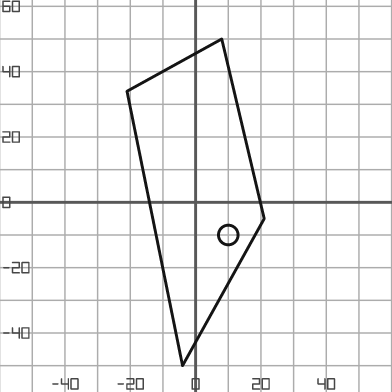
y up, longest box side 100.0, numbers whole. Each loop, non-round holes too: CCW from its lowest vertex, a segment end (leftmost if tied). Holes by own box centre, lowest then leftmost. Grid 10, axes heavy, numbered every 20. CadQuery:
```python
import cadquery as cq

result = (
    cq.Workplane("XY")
    .moveTo(-4.0, -50.0)
    .lineTo(21.0, -5.0)
    .lineTo(8.0, 50.0)
    .lineTo(-21.0, 34.0)
    .close()
    .moveTo(10.0, -10.0)
    .circle(3.0)
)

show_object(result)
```